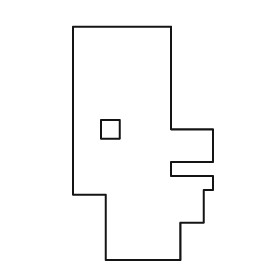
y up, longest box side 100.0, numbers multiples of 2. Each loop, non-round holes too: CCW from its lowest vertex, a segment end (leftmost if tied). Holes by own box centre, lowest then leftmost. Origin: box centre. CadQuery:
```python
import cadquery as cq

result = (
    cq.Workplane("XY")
    .moveTo(-16.0, -50.0)
    .lineTo(16.0, -50.0)
    .lineTo(16.0, -34.0)
    .lineTo(26.0, -34.0)
    .lineTo(26.0, -20.0)
    .lineTo(30.0, -20.0)
    .lineTo(30.0, -14.0)
    .lineTo(12.0, -14.0)
    .lineTo(12.0, -8.0)
    .lineTo(30.0, -8.0)
    .lineTo(30.0, 6.0)
    .lineTo(12.0, 6.0)
    .lineTo(12.0, 50.0)
    .lineTo(-30.0, 50.0)
    .lineTo(-30.0, -22.0)
    .lineTo(-16.0, -22.0)
    .close()
    .moveTo(-18.0, 2.0)
    .lineTo(-10.0, 2.0)
    .lineTo(-10.0, 10.0)
    .lineTo(-18.0, 10.0)
    .close()
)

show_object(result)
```